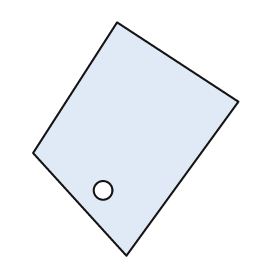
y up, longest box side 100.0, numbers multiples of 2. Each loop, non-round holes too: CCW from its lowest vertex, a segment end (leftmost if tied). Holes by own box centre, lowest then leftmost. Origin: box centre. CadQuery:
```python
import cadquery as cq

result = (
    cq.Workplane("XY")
    .moveTo(-4.0, -50.0)
    .lineTo(44.0, 16.0)
    .lineTo(-8.0, 50.0)
    .lineTo(-44.0, -6.0)
    .close()
    .moveTo(-14.0, -22.0)
    .circle(4.0)
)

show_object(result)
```